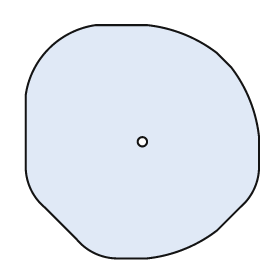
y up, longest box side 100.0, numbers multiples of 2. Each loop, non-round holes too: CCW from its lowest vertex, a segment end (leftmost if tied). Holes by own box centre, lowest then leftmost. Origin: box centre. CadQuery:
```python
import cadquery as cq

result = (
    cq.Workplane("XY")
    .moveTo(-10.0, -50.0)
    .lineTo(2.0, -50.0)
    .threePointArc((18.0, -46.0), (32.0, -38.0))
    .lineTo(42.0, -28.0)
    .threePointArc((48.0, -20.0), (50.0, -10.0))
    .lineTo(50.0, 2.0)
    .threePointArc((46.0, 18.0), (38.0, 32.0))
    .lineTo(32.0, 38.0)
    .threePointArc((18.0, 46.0), (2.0, 50.0))
    .lineTo(-20.0, 50.0)
    .threePointArc((-40.0, 40.0), (-50.0, 20.0))
    .lineTo(-50.0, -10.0)
    .threePointArc((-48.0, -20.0), (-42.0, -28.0))
    .lineTo(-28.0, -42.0)
    .threePointArc((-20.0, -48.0), (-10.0, -50.0))
    .close()
    .moveTo(0.0, 0.0)
    .circle(2.0)
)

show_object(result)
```